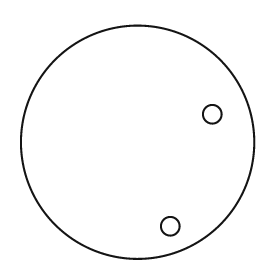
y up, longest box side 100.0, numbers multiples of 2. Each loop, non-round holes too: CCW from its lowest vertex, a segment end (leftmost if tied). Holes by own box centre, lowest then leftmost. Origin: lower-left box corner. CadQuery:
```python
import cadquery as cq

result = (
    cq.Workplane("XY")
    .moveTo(50.0, 50.0)
    .circle(50.0)
    .moveTo(64.0, 14.0)
    .circle(4.0)
    .moveTo(82.0, 62.0)
    .circle(4.0)
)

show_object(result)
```